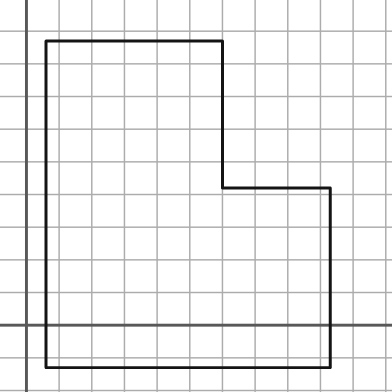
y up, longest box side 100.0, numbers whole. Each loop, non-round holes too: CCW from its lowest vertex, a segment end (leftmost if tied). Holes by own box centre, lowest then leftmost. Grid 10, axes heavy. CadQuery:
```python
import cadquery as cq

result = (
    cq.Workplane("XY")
    .moveTo(6.0, -13.0)
    .lineTo(93.0, -13.0)
    .lineTo(93.0, 42.0)
    .lineTo(60.0, 42.0)
    .lineTo(60.0, 87.0)
    .lineTo(6.0, 87.0)
    .close()
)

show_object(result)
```